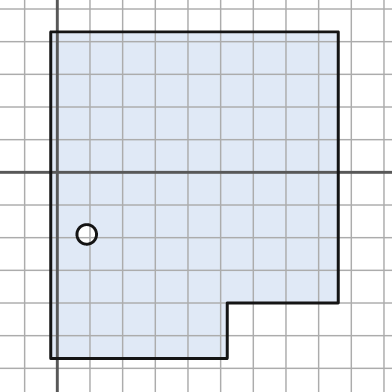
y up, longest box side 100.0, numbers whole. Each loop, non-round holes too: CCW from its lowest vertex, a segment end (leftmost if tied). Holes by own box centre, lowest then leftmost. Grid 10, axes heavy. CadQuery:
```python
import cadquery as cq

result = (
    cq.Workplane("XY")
    .moveTo(-2.0, -57.0)
    .lineTo(52.0, -57.0)
    .lineTo(52.0, -40.0)
    .lineTo(86.0, -40.0)
    .lineTo(86.0, 43.0)
    .lineTo(-2.0, 43.0)
    .close()
    .moveTo(9.0, -19.0)
    .circle(3.0)
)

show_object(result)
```